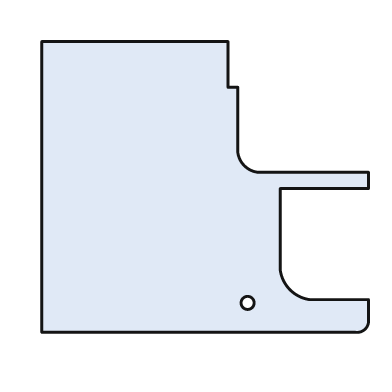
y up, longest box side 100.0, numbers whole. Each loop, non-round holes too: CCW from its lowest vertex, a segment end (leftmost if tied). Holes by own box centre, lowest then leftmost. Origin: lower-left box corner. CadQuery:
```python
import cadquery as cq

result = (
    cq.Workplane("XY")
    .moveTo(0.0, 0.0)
    .lineTo(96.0, 0.0)
    .threePointArc((99.0, 1.0), (100.0, 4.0))
    .lineTo(100.0, 10.0)
    .lineTo(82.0, 10.0)
    .threePointArc((76.0, 13.0), (73.0, 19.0))
    .lineTo(73.0, 44.0)
    .lineTo(100.0, 44.0)
    .lineTo(100.0, 49.0)
    .lineTo(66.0, 49.0)
    .threePointArc((62.0, 51.0), (60.0, 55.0))
    .lineTo(60.0, 75.0)
    .lineTo(57.0, 75.0)
    .lineTo(57.0, 89.0)
    .lineTo(0.0, 89.0)
    .close()
    .moveTo(63.0, 9.0)
    .circle(2.0)
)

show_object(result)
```